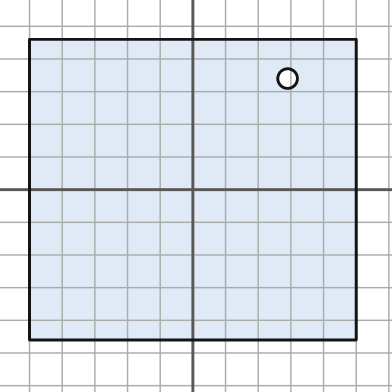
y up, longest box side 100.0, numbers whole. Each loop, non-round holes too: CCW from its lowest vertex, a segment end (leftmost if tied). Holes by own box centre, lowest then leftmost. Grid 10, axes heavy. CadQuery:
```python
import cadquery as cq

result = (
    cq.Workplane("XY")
    .moveTo(-50.0, -46.0)
    .lineTo(50.0, -46.0)
    .lineTo(50.0, 46.0)
    .lineTo(-50.0, 46.0)
    .close()
    .moveTo(29.0, 34.0)
    .circle(3.0)
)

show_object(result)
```